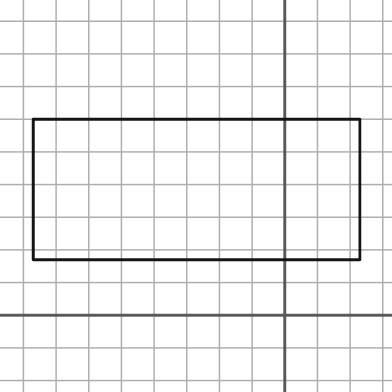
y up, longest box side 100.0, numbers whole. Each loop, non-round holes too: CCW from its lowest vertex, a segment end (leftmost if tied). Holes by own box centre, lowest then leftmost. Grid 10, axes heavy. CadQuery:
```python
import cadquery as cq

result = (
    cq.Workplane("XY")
    .moveTo(-77.0, 17.0)
    .lineTo(23.0, 17.0)
    .lineTo(23.0, 60.0)
    .lineTo(-77.0, 60.0)
    .close()
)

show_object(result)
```